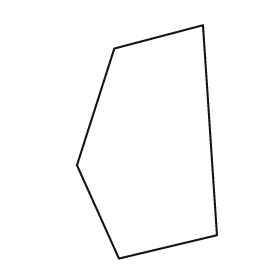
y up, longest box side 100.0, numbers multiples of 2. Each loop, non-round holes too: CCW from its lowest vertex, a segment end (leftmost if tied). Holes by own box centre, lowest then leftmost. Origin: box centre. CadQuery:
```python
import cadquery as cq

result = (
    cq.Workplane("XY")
    .moveTo(-12.0, -50.0)
    .lineTo(30.0, -40.0)
    .lineTo(24.0, 50.0)
    .lineTo(-14.0, 40.0)
    .lineTo(-30.0, -10.0)
    .close()
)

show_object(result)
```